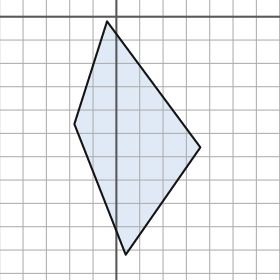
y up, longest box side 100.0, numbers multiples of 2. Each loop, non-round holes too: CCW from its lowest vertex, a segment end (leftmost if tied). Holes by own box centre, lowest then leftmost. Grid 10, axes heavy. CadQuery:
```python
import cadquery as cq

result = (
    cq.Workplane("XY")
    .moveTo(4.0, -102.0)
    .lineTo(36.0, -56.0)
    .lineTo(-4.0, -2.0)
    .lineTo(-18.0, -46.0)
    .close()
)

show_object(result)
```